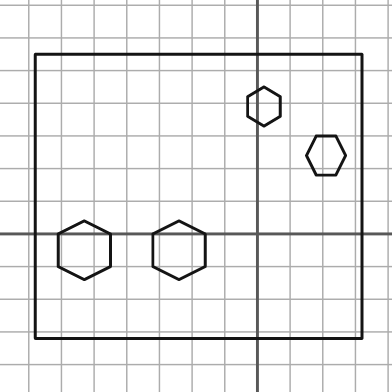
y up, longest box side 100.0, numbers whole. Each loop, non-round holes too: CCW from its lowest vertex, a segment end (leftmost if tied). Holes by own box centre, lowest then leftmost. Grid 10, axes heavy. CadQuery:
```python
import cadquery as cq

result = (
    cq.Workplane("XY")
    .moveTo(-68.0, -32.0)
    .lineTo(32.0, -32.0)
    .lineTo(32.0, 55.0)
    .lineTo(-68.0, 55.0)
    .close()
    .moveTo(-53.0, -14.0)
    .lineTo(-45.0, -10.0)
    .lineTo(-45.0, 0.0)
    .lineTo(-53.0, 4.0)
    .lineTo(-61.0, 0.0)
    .lineTo(-61.0, -10.0)
    .close()
    .moveTo(-24.0, -14.0)
    .lineTo(-16.0, -10.0)
    .lineTo(-16.0, 0.0)
    .lineTo(-24.0, 4.0)
    .lineTo(-32.0, 0.0)
    .lineTo(-32.0, -10.0)
    .close()
    .moveTo(18.0, 18.0)
    .lineTo(24.0, 18.0)
    .lineTo(27.0, 24.0)
    .lineTo(24.0, 30.0)
    .lineTo(18.0, 30.0)
    .lineTo(15.0, 24.0)
    .close()
    .moveTo(2.0, 33.0)
    .lineTo(7.0, 36.0)
    .lineTo(7.0, 42.0)
    .lineTo(2.0, 45.0)
    .lineTo(-3.0, 42.0)
    .lineTo(-3.0, 36.0)
    .close()
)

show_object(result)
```